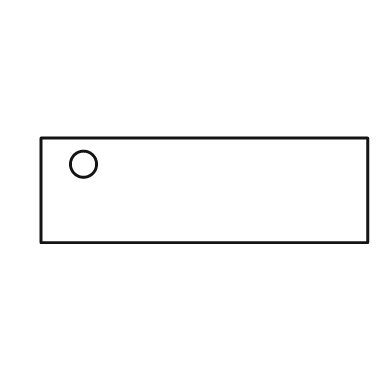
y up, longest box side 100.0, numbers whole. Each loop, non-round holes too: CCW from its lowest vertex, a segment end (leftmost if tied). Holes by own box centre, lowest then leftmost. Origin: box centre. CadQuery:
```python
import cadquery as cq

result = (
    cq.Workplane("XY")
    .moveTo(-50.0, -16.0)
    .lineTo(50.0, -16.0)
    .lineTo(50.0, 16.0)
    .lineTo(-50.0, 16.0)
    .close()
    .moveTo(-37.0, 8.0)
    .circle(4.0)
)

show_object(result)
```